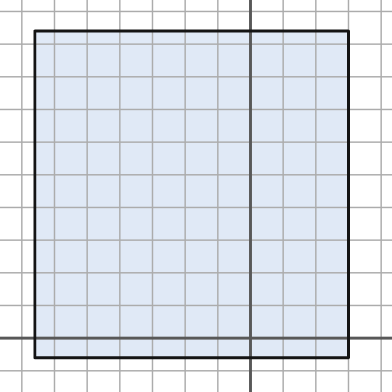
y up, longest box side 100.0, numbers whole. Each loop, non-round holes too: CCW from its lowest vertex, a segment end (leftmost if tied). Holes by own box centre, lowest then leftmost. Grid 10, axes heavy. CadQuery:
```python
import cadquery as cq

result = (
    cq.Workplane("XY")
    .moveTo(-66.0, -6.0)
    .lineTo(30.0, -6.0)
    .lineTo(30.0, 94.0)
    .lineTo(-66.0, 94.0)
    .close()
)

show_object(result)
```